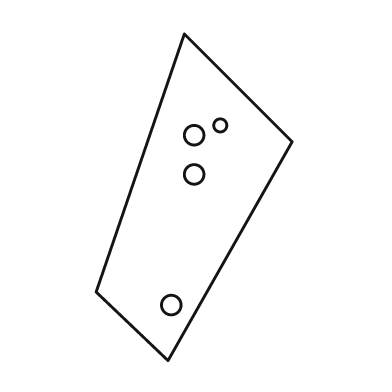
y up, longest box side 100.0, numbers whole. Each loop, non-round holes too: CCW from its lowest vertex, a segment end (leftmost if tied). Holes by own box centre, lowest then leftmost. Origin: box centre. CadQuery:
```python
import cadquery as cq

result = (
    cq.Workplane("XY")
    .moveTo(-8.0, -50.0)
    .lineTo(30.0, 17.0)
    .lineTo(-3.0, 50.0)
    .lineTo(-30.0, -29.0)
    .close()
    .moveTo(-7.0, -33.0)
    .circle(3.0)
    .moveTo(0.0, 7.0)
    .circle(3.0)
    .moveTo(0.0, 19.0)
    .circle(3.0)
    .moveTo(8.0, 22.0)
    .circle(2.0)
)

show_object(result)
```